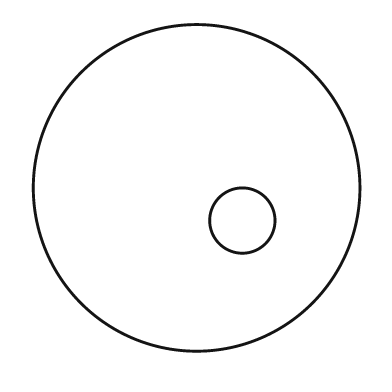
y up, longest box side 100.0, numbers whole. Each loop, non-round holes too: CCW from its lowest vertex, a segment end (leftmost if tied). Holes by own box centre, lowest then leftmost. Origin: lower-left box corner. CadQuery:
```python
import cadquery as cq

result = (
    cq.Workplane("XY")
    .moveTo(50.0, 50.0)
    .circle(50.0)
    .moveTo(64.0, 40.0)
    .circle(10.0)
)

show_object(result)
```